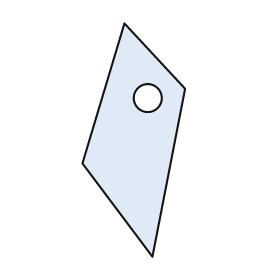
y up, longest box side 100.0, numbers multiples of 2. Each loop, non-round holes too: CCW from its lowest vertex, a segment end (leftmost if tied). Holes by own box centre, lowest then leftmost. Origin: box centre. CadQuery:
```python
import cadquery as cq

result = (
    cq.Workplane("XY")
    .moveTo(8.0, -50.0)
    .lineTo(22.0, 22.0)
    .lineTo(-4.0, 50.0)
    .lineTo(-22.0, -10.0)
    .close()
    .moveTo(6.0, 18.0)
    .circle(6.0)
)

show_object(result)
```